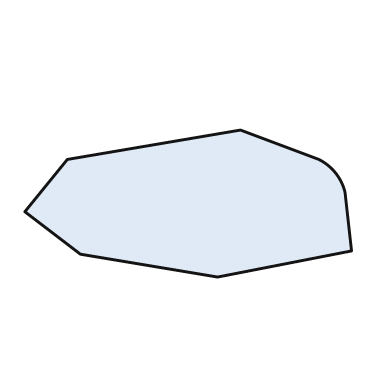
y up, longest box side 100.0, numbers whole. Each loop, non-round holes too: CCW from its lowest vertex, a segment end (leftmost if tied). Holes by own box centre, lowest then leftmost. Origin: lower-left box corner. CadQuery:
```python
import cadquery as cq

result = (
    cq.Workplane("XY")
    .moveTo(59.0, 0.0)
    .lineTo(100.0, 8.0)
    .lineTo(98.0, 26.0)
    .threePointArc((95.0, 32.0), (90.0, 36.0))
    .lineTo(66.0, 45.0)
    .lineTo(13.0, 36.0)
    .lineTo(0.0, 20.0)
    .lineTo(17.0, 7.0)
    .close()
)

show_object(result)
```